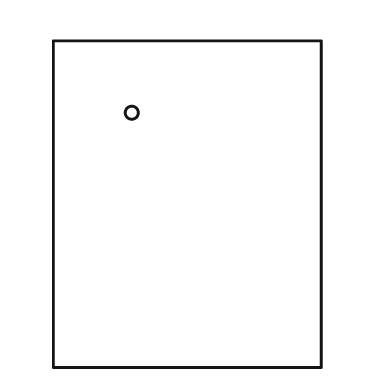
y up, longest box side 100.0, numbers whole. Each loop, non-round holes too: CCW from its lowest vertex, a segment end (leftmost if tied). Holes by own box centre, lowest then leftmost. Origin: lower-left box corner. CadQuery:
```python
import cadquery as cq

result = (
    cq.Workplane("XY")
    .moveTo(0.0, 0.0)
    .lineTo(82.0, 0.0)
    .lineTo(82.0, 100.0)
    .lineTo(0.0, 100.0)
    .close()
    .moveTo(24.0, 78.0)
    .circle(2.0)
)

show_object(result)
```